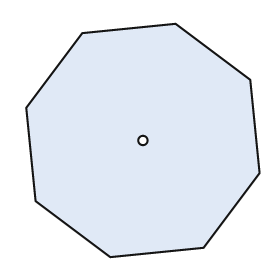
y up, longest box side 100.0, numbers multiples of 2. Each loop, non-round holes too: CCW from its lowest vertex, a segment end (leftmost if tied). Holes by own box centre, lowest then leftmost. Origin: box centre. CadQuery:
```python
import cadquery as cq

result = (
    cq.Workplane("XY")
    .moveTo(-14.0, -50.0)
    .lineTo(26.0, -46.0)
    .lineTo(50.0, -14.0)
    .lineTo(46.0, 26.0)
    .lineTo(14.0, 50.0)
    .lineTo(-26.0, 46.0)
    .lineTo(-50.0, 14.0)
    .lineTo(-46.0, -26.0)
    .close()
    .moveTo(0.0, 0.0)
    .circle(2.0)
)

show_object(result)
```